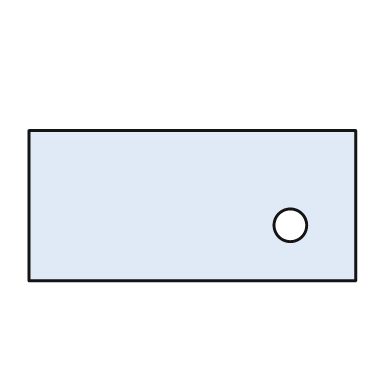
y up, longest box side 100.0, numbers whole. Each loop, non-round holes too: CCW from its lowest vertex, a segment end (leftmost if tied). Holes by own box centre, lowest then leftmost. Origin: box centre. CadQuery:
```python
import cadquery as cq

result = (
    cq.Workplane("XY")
    .moveTo(-50.0, -23.0)
    .lineTo(50.0, -23.0)
    .lineTo(50.0, 23.0)
    .lineTo(-50.0, 23.0)
    .close()
    .moveTo(30.0, -6.0)
    .circle(5.0)
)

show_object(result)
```